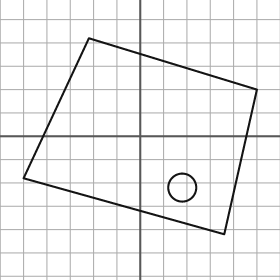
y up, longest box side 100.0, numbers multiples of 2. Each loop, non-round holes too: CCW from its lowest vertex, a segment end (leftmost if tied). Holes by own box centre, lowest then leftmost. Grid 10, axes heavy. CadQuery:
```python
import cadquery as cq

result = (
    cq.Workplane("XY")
    .moveTo(36.0, -42.0)
    .lineTo(50.0, 20.0)
    .lineTo(-22.0, 42.0)
    .lineTo(-50.0, -18.0)
    .close()
    .moveTo(18.0, -22.0)
    .circle(6.0)
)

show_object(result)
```